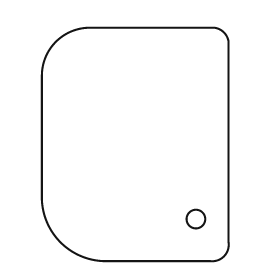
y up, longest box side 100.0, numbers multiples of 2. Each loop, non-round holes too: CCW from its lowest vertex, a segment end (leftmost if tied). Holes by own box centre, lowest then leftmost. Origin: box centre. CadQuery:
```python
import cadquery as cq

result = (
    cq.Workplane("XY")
    .moveTo(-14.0, -50.0)
    .lineTo(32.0, -50.0)
    .threePointArc((38.0, -48.0), (40.0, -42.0))
    .lineTo(40.0, 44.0)
    .threePointArc((38.0, 48.0), (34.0, 50.0))
    .lineTo(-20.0, 50.0)
    .threePointArc((-34.0, 44.0), (-40.0, 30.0))
    .lineTo(-40.0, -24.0)
    .threePointArc((-32.0, -42.0), (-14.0, -50.0))
    .close()
    .moveTo(26.0, -32.0)
    .circle(4.0)
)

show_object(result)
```